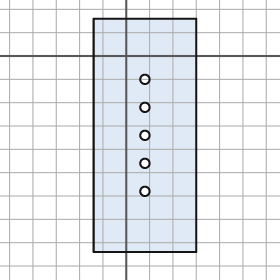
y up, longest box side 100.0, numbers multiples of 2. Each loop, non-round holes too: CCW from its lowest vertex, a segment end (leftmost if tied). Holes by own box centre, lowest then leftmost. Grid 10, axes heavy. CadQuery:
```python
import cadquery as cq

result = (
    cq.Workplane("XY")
    .moveTo(-14.0, -84.0)
    .lineTo(30.0, -84.0)
    .lineTo(30.0, 16.0)
    .lineTo(-14.0, 16.0)
    .close()
    .moveTo(8.0, -58.0)
    .circle(2.0)
    .moveTo(8.0, -46.0)
    .circle(2.0)
    .moveTo(8.0, -34.0)
    .circle(2.0)
    .moveTo(8.0, -22.0)
    .circle(2.0)
    .moveTo(8.0, -10.0)
    .circle(2.0)
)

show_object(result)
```